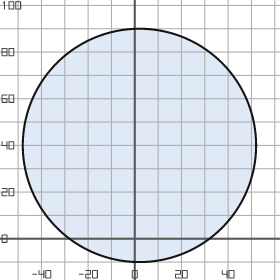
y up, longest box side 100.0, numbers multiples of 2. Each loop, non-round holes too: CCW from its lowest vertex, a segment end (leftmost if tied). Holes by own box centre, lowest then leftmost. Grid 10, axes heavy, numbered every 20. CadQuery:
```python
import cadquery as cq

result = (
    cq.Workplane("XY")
    .moveTo(2.0, 40.0)
    .circle(50.0)
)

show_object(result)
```